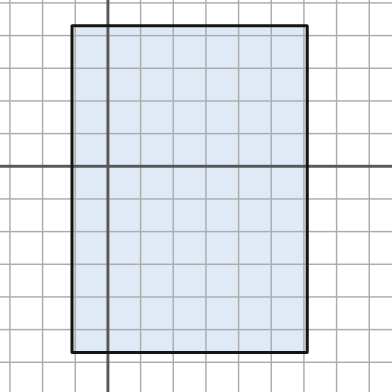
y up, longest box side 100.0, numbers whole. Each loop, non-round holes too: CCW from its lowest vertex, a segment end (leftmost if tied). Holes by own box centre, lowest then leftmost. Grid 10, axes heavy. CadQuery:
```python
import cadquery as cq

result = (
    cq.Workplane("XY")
    .moveTo(-11.0, -57.0)
    .lineTo(61.0, -57.0)
    .lineTo(61.0, 43.0)
    .lineTo(-11.0, 43.0)
    .close()
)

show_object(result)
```